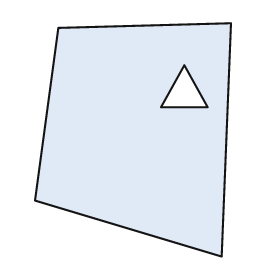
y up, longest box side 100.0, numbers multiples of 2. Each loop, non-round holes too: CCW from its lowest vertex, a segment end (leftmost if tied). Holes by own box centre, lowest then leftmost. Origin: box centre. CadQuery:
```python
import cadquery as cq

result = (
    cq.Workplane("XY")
    .moveTo(38.0, -50.0)
    .lineTo(42.0, 50.0)
    .lineTo(-32.0, 48.0)
    .lineTo(-42.0, -26.0)
    .close()
    .moveTo(12.0, 14.0)
    .lineTo(32.0, 14.0)
    .lineTo(22.0, 32.0)
    .close()
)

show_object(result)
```